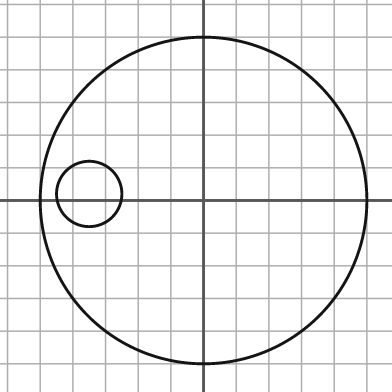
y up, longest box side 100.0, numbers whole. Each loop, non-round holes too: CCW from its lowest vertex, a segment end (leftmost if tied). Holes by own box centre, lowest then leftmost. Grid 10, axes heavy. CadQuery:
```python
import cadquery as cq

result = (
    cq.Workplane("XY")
    .moveTo(0.0, 0.0)
    .circle(50.0)
    .moveTo(-35.0, 2.0)
    .circle(10.0)
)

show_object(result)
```